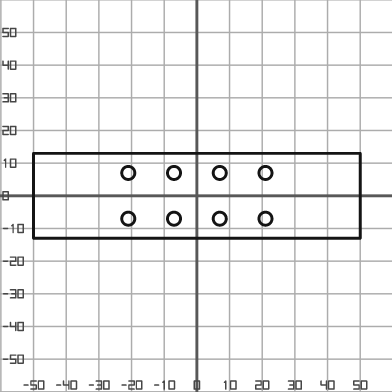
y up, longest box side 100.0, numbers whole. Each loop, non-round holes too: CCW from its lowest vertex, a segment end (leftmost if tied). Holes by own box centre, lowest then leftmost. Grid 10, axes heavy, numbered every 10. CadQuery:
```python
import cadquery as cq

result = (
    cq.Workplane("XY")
    .moveTo(-50.0, -13.0)
    .lineTo(50.0, -13.0)
    .lineTo(50.0, 13.0)
    .lineTo(-50.0, 13.0)
    .close()
    .moveTo(-21.0, -7.0)
    .circle(2.0)
    .moveTo(-7.0, -7.0)
    .circle(2.0)
    .moveTo(7.0, -7.0)
    .circle(2.0)
    .moveTo(21.0, -7.0)
    .circle(2.0)
    .moveTo(-21.0, 7.0)
    .circle(2.0)
    .moveTo(-7.0, 7.0)
    .circle(2.0)
    .moveTo(7.0, 7.0)
    .circle(2.0)
    .moveTo(21.0, 7.0)
    .circle(2.0)
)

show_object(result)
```